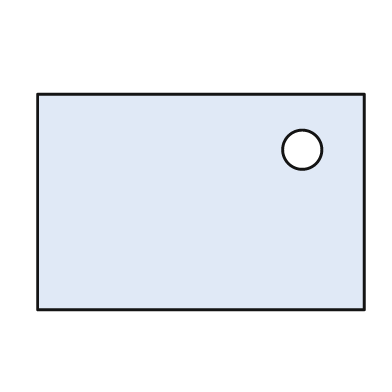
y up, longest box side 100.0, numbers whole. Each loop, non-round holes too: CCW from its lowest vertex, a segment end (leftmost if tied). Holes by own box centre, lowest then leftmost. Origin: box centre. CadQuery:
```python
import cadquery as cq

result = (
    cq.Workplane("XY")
    .moveTo(-50.0, -33.0)
    .lineTo(50.0, -33.0)
    .lineTo(50.0, 33.0)
    .lineTo(-50.0, 33.0)
    .close()
    .moveTo(31.0, 16.0)
    .circle(6.0)
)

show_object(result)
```